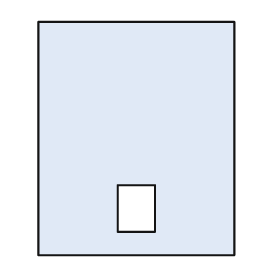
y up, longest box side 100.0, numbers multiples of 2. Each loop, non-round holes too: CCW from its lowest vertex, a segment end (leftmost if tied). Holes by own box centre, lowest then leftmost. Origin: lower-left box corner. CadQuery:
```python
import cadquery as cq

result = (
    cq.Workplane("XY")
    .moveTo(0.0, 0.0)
    .lineTo(84.0, 0.0)
    .lineTo(84.0, 100.0)
    .lineTo(0.0, 100.0)
    .close()
    .moveTo(34.0, 10.0)
    .lineTo(50.0, 10.0)
    .lineTo(50.0, 30.0)
    .lineTo(34.0, 30.0)
    .close()
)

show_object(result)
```